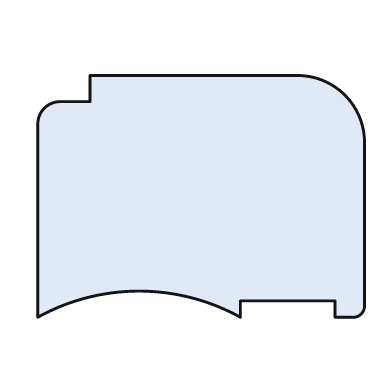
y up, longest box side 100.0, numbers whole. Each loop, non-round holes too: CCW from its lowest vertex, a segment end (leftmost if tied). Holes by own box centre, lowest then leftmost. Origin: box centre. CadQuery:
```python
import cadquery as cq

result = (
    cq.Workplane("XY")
    .moveTo(-50.0, -37.0)
    .threePointArc((-19.0, -29.0), (12.0, -37.0))
    .lineTo(12.0, -32.0)
    .lineTo(41.0, -32.0)
    .lineTo(41.0, -37.0)
    .lineTo(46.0, -37.0)
    .threePointArc((49.0, -36.0), (50.0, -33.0))
    .lineTo(50.0, 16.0)
    .threePointArc((44.0, 31.0), (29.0, 37.0))
    .lineTo(-34.0, 37.0)
    .lineTo(-34.0, 29.0)
    .lineTo(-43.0, 29.0)
    .threePointArc((-48.0, 27.0), (-50.0, 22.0))
    .close()
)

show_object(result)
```